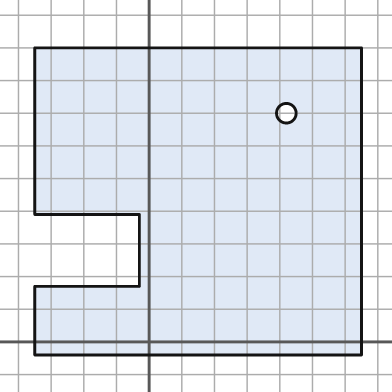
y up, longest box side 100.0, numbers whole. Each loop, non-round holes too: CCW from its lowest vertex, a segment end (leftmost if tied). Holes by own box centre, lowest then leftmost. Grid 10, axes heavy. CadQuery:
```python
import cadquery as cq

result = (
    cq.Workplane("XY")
    .moveTo(-35.0, -4.0)
    .lineTo(65.0, -4.0)
    .lineTo(65.0, 90.0)
    .lineTo(-35.0, 90.0)
    .lineTo(-35.0, 39.0)
    .lineTo(-3.0, 39.0)
    .lineTo(-3.0, 17.0)
    .lineTo(-35.0, 17.0)
    .close()
    .moveTo(42.0, 70.0)
    .circle(3.0)
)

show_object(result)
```